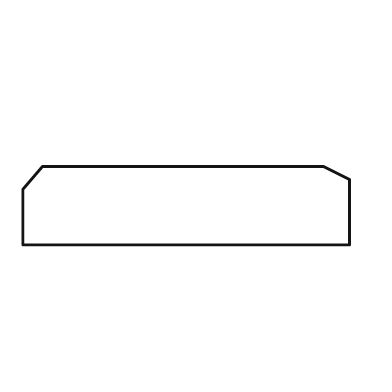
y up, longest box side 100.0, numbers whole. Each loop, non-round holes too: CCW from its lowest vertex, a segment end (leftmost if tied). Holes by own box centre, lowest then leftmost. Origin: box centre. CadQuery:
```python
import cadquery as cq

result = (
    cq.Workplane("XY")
    .moveTo(-50.0, -12.0)
    .lineTo(50.0, -12.0)
    .lineTo(50.0, 8.0)
    .lineTo(42.0, 12.0)
    .lineTo(-44.0, 12.0)
    .lineTo(-50.0, 5.0)
    .close()
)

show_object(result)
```